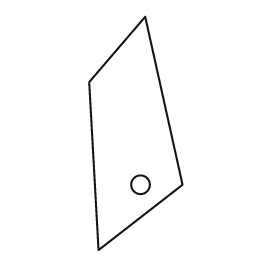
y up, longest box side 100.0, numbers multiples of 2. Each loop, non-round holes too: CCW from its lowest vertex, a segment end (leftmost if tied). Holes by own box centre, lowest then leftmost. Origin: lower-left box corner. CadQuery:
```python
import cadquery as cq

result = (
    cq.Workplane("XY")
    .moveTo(4.0, 0.0)
    .lineTo(40.0, 28.0)
    .lineTo(24.0, 100.0)
    .lineTo(0.0, 72.0)
    .close()
    .moveTo(22.0, 28.0)
    .circle(4.0)
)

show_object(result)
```